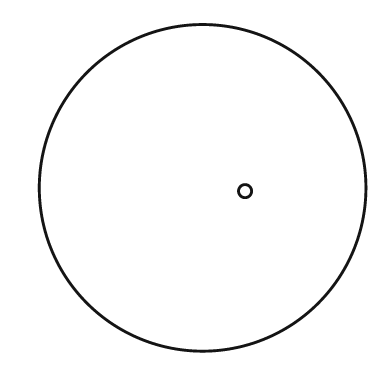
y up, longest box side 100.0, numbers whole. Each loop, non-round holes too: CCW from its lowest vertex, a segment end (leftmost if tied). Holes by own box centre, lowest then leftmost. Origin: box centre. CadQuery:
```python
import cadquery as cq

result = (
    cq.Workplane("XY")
    .moveTo(0.0, 0.0)
    .circle(50.0)
    .moveTo(13.0, -1.0)
    .circle(2.0)
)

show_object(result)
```